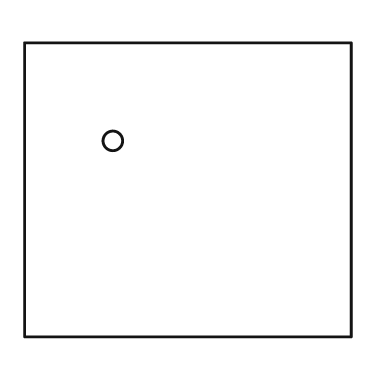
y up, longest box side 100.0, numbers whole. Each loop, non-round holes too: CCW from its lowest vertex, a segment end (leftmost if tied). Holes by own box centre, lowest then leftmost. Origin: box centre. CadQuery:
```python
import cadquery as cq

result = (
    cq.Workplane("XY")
    .moveTo(-50.0, -45.0)
    .lineTo(50.0, -45.0)
    .lineTo(50.0, 45.0)
    .lineTo(-50.0, 45.0)
    .close()
    .moveTo(-23.0, 15.0)
    .circle(3.0)
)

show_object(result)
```